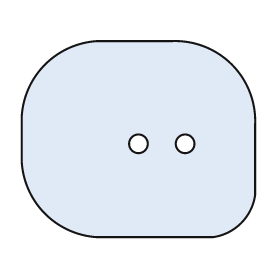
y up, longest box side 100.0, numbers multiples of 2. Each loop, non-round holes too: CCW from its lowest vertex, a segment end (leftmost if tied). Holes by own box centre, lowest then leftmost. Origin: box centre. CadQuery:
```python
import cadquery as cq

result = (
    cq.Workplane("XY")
    .moveTo(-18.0, -42.0)
    .lineTo(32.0, -42.0)
    .threePointArc((44.0, -36.0), (50.0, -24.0))
    .lineTo(50.0, 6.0)
    .threePointArc((40.0, 32.0), (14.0, 42.0))
    .lineTo(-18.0, 42.0)
    .threePointArc((-40.0, 32.0), (-50.0, 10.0))
    .lineTo(-50.0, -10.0)
    .threePointArc((-40.0, -32.0), (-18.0, -42.0))
    .close()
    .moveTo(0.0, -2.0)
    .circle(4.0)
    .moveTo(20.0, -2.0)
    .circle(4.0)
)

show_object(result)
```